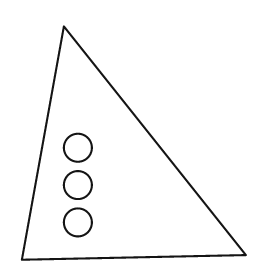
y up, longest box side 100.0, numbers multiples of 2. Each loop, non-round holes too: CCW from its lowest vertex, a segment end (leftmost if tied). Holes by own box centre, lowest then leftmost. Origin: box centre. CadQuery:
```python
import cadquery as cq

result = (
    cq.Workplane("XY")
    .moveTo(-48.0, -50.0)
    .lineTo(48.0, -48.0)
    .lineTo(-30.0, 50.0)
    .close()
    .moveTo(-24.0, -34.0)
    .circle(6.0)
    .moveTo(-24.0, -18.0)
    .circle(6.0)
    .moveTo(-24.0, -2.0)
    .circle(6.0)
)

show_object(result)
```